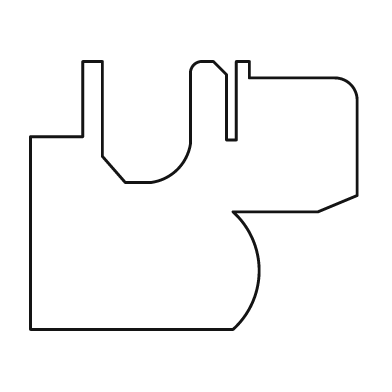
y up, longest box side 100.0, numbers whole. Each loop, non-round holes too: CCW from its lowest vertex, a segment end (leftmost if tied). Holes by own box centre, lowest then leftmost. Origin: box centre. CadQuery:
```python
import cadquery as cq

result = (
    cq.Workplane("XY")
    .moveTo(-50.0, -41.0)
    .lineTo(12.0, -41.0)
    .threePointArc((20.0, -23.0), (12.0, -5.0))
    .lineTo(38.0, -5.0)
    .lineTo(50.0, 0.0)
    .lineTo(50.0, 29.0)
    .threePointArc((48.0, 34.0), (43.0, 36.0))
    .lineTo(17.0, 36.0)
    .lineTo(17.0, 41.0)
    .lineTo(13.0, 41.0)
    .lineTo(13.0, 17.0)
    .lineTo(10.0, 17.0)
    .lineTo(10.0, 37.0)
    .lineTo(6.0, 41.0)
    .lineTo(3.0, 41.0)
    .threePointArc((0.0, 40.0), (-1.0, 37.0))
    .lineTo(-1.0, 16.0)
    .threePointArc((-5.0, 8.0), (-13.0, 4.0))
    .lineTo(-21.0, 4.0)
    .lineTo(-28.0, 12.0)
    .lineTo(-28.0, 41.0)
    .lineTo(-34.0, 41.0)
    .lineTo(-34.0, 18.0)
    .lineTo(-50.0, 18.0)
    .close()
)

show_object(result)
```